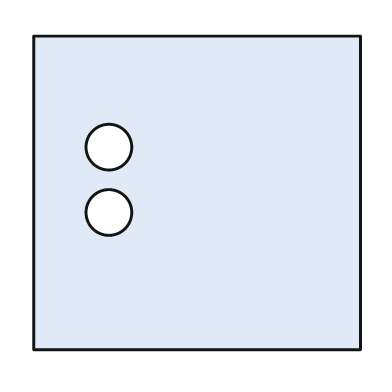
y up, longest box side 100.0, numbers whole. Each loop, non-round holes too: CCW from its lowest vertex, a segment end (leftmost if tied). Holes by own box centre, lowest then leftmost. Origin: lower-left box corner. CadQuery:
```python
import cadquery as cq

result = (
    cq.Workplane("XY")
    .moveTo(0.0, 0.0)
    .lineTo(100.0, 0.0)
    .lineTo(100.0, 96.0)
    .lineTo(0.0, 96.0)
    .close()
    .moveTo(23.0, 42.0)
    .circle(7.0)
    .moveTo(23.0, 62.0)
    .circle(7.0)
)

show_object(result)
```